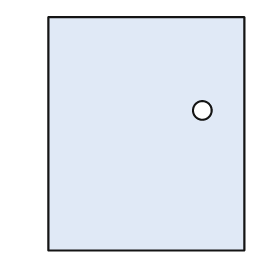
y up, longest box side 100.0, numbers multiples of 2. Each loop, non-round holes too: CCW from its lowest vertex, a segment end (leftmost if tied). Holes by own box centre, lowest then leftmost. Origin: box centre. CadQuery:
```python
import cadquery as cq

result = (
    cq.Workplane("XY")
    .moveTo(-42.0, -50.0)
    .lineTo(42.0, -50.0)
    .lineTo(42.0, 50.0)
    .lineTo(-42.0, 50.0)
    .close()
    .moveTo(24.0, 10.0)
    .circle(4.0)
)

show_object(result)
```